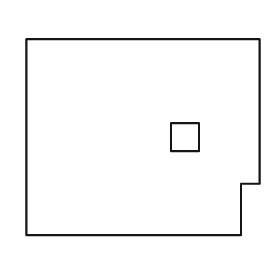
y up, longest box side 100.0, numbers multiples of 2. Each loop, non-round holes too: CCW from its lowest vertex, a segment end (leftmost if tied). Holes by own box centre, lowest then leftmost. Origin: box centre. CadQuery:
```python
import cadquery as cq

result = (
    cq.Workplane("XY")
    .moveTo(-50.0, -42.0)
    .lineTo(42.0, -42.0)
    .lineTo(42.0, -20.0)
    .lineTo(50.0, -20.0)
    .lineTo(50.0, 42.0)
    .lineTo(-50.0, 42.0)
    .close()
    .moveTo(12.0, -6.0)
    .lineTo(24.0, -6.0)
    .lineTo(24.0, 6.0)
    .lineTo(12.0, 6.0)
    .close()
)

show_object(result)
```